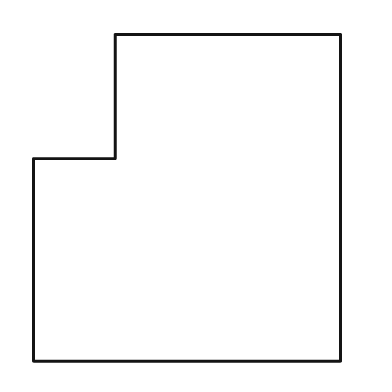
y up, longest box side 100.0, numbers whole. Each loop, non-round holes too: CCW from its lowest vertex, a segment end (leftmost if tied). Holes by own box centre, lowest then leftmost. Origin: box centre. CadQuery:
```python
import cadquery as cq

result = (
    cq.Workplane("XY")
    .moveTo(-47.0, -50.0)
    .lineTo(47.0, -50.0)
    .lineTo(47.0, 50.0)
    .lineTo(-22.0, 50.0)
    .lineTo(-22.0, 12.0)
    .lineTo(-47.0, 12.0)
    .close()
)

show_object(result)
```